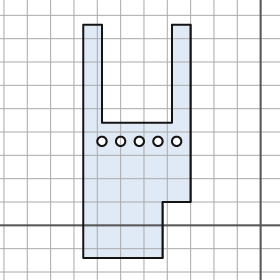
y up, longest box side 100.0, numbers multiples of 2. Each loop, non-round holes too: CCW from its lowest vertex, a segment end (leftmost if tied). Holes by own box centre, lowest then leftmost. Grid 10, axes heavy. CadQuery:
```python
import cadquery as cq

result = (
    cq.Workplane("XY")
    .moveTo(-76.0, -14.0)
    .lineTo(-42.0, -14.0)
    .lineTo(-42.0, 10.0)
    .lineTo(-30.0, 10.0)
    .lineTo(-30.0, 86.0)
    .lineTo(-38.0, 86.0)
    .lineTo(-38.0, 44.0)
    .lineTo(-68.0, 44.0)
    .lineTo(-68.0, 86.0)
    .lineTo(-76.0, 86.0)
    .close()
    .moveTo(-68.0, 36.0)
    .circle(2.0)
    .moveTo(-60.0, 36.0)
    .circle(2.0)
    .moveTo(-52.0, 36.0)
    .circle(2.0)
    .moveTo(-44.0, 36.0)
    .circle(2.0)
    .moveTo(-36.0, 36.0)
    .circle(2.0)
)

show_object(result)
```